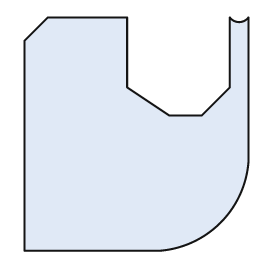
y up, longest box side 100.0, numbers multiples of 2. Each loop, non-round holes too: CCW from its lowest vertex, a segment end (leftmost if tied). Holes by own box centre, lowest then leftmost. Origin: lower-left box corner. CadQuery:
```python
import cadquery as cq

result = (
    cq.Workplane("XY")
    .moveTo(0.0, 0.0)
    .lineTo(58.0, 0.0)
    .threePointArc((84.0, 12.0), (96.0, 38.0))
    .lineTo(96.0, 100.0)
    .threePointArc((92.0, 98.0), (88.0, 100.0))
    .lineTo(88.0, 70.0)
    .lineTo(76.0, 58.0)
    .lineTo(62.0, 58.0)
    .lineTo(44.0, 70.0)
    .lineTo(44.0, 100.0)
    .lineTo(10.0, 100.0)
    .lineTo(0.0, 90.0)
    .close()
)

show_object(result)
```